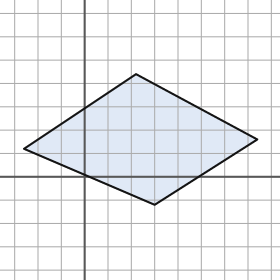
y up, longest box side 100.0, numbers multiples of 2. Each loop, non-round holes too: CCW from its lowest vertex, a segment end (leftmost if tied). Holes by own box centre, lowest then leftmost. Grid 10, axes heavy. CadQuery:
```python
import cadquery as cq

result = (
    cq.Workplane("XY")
    .moveTo(30.0, -12.0)
    .lineTo(74.0, 16.0)
    .lineTo(22.0, 44.0)
    .lineTo(-26.0, 12.0)
    .close()
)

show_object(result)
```